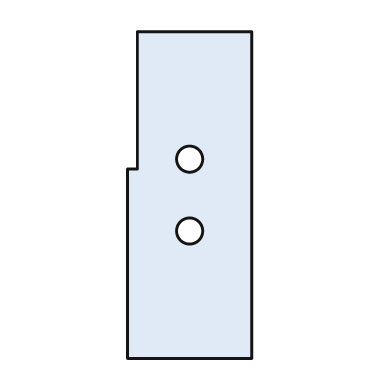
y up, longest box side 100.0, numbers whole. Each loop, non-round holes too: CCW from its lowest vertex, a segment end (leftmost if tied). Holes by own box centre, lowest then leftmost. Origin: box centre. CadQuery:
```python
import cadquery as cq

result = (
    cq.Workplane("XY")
    .moveTo(-19.0, -50.0)
    .lineTo(19.0, -50.0)
    .lineTo(19.0, 50.0)
    .lineTo(-16.0, 50.0)
    .lineTo(-16.0, 8.0)
    .lineTo(-19.0, 8.0)
    .close()
    .moveTo(0.0, -11.0)
    .circle(4.0)
    .moveTo(0.0, 11.0)
    .circle(4.0)
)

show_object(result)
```